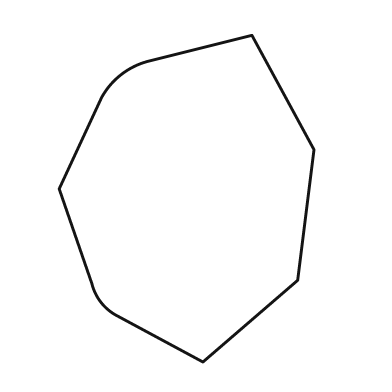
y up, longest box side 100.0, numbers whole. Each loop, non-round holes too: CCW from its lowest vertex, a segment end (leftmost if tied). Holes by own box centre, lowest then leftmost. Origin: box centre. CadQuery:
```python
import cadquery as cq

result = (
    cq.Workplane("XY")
    .moveTo(5.0, -50.0)
    .lineTo(34.0, -25.0)
    .lineTo(39.0, 15.0)
    .lineTo(20.0, 50.0)
    .lineTo(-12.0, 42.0)
    .threePointArc((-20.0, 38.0), (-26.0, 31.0))
    .lineTo(-39.0, 3.0)
    .lineTo(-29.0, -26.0)
    .threePointArc((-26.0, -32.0), (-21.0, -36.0))
    .close()
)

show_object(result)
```